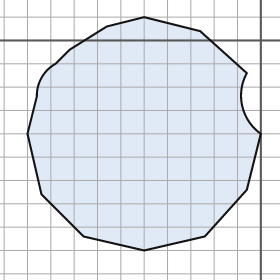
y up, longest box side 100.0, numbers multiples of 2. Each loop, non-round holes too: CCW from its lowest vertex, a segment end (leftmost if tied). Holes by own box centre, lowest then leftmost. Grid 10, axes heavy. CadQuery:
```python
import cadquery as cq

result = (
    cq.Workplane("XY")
    .moveTo(-50.0, -90.0)
    .lineTo(-24.0, -84.0)
    .lineTo(-6.0, -64.0)
    .lineTo(0.0, -40.0)
    .threePointArc((-8.0, -28.0), (-6.0, -14.0))
    .lineTo(-26.0, 4.0)
    .lineTo(-50.0, 10.0)
    .lineTo(-66.0, 6.0)
    .lineTo(-82.0, -4.0)
    .lineTo(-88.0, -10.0)
    .threePointArc((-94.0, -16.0), (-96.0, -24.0))
    .lineTo(-100.0, -40.0)
    .lineTo(-94.0, -66.0)
    .lineTo(-76.0, -84.0)
    .close()
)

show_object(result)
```